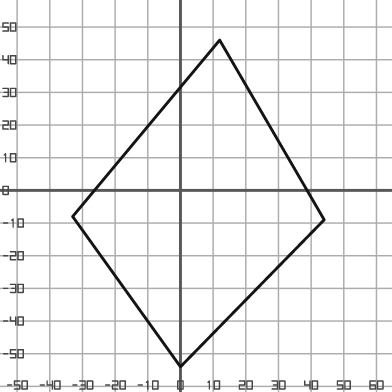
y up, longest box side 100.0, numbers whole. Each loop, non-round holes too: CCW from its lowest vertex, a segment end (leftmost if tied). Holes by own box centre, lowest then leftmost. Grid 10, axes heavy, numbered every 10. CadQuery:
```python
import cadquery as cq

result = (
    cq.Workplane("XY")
    .moveTo(0.0, -54.0)
    .lineTo(44.0, -9.0)
    .lineTo(12.0, 46.0)
    .lineTo(-33.0, -8.0)
    .close()
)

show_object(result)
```